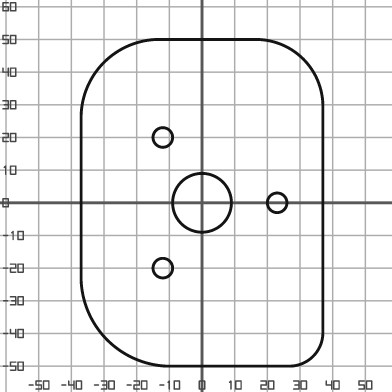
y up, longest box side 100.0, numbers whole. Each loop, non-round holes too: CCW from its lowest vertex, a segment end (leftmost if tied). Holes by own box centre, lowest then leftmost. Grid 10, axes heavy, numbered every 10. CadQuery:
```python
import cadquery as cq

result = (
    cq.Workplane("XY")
    .moveTo(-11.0, -50.0)
    .lineTo(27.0, -50.0)
    .threePointArc((34.0, -47.0), (37.0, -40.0))
    .lineTo(37.0, 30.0)
    .threePointArc((31.0, 44.0), (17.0, 50.0))
    .lineTo(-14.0, 50.0)
    .threePointArc((-30.0, 43.0), (-37.0, 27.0))
    .lineTo(-37.0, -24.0)
    .threePointArc((-29.0, -42.0), (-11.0, -50.0))
    .close()
    .moveTo(-12.0, -20.0)
    .circle(3.0)
    .moveTo(0.0, 0.0)
    .circle(9.0)
    .moveTo(23.0, 0.0)
    .circle(3.0)
    .moveTo(-12.0, 20.0)
    .circle(3.0)
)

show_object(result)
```